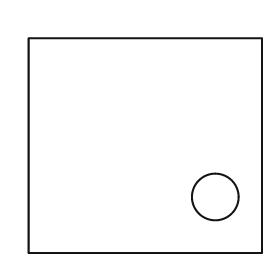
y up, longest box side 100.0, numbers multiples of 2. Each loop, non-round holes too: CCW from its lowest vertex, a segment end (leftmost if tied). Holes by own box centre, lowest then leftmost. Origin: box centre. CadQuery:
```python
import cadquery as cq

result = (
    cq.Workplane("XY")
    .moveTo(-50.0, -46.0)
    .lineTo(50.0, -46.0)
    .lineTo(50.0, 46.0)
    .lineTo(-50.0, 46.0)
    .close()
    .moveTo(30.0, -22.0)
    .circle(10.0)
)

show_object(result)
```